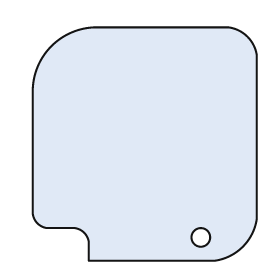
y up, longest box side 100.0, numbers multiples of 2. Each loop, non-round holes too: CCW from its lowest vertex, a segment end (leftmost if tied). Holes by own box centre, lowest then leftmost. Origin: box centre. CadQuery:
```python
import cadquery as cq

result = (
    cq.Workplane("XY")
    .moveTo(-24.0, -50.0)
    .lineTo(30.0, -50.0)
    .threePointArc((42.0, -44.0), (48.0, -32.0))
    .lineTo(48.0, 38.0)
    .threePointArc((44.0, 46.0), (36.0, 50.0))
    .lineTo(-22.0, 50.0)
    .threePointArc((-40.0, 42.0), (-48.0, 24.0))
    .lineTo(-48.0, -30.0)
    .threePointArc((-46.0, -34.0), (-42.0, -36.0))
    .lineTo(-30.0, -36.0)
    .threePointArc((-26.0, -38.0), (-24.0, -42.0))
    .close()
    .moveTo(24.0, -40.0)
    .circle(4.0)
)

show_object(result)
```